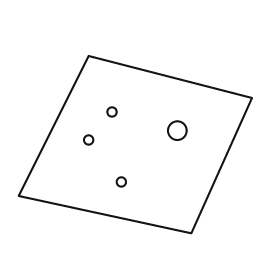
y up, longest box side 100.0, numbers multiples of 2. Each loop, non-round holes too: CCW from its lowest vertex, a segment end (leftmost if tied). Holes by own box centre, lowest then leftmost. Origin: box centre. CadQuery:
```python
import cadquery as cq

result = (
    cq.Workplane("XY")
    .moveTo(24.0, -38.0)
    .lineTo(50.0, 20.0)
    .lineTo(-20.0, 38.0)
    .lineTo(-50.0, -22.0)
    .close()
    .moveTo(-6.0, -16.0)
    .circle(2.0)
    .moveTo(-20.0, 2.0)
    .circle(2.0)
    .moveTo(18.0, 6.0)
    .circle(4.0)
    .moveTo(-10.0, 14.0)
    .circle(2.0)
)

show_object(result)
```